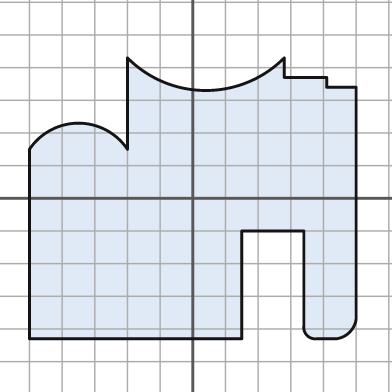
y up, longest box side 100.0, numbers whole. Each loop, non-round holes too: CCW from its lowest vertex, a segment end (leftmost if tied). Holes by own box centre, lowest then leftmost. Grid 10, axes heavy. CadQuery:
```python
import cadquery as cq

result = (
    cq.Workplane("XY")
    .moveTo(-50.0, -43.0)
    .lineTo(15.0, -43.0)
    .lineTo(15.0, -10.0)
    .lineTo(34.0, -10.0)
    .lineTo(34.0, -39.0)
    .threePointArc((35.0, -42.0), (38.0, -43.0))
    .lineTo(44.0, -43.0)
    .threePointArc((48.0, -41.0), (50.0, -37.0))
    .lineTo(50.0, 34.0)
    .lineTo(41.0, 34.0)
    .lineTo(41.0, 37.0)
    .lineTo(28.0, 37.0)
    .lineTo(28.0, 43.0)
    .threePointArc((4.0, 33.0), (-20.0, 43.0))
    .lineTo(-20.0, 15.0)
    .threePointArc((-35.0, 23.0), (-50.0, 15.0))
    .close()
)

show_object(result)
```